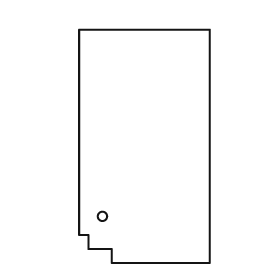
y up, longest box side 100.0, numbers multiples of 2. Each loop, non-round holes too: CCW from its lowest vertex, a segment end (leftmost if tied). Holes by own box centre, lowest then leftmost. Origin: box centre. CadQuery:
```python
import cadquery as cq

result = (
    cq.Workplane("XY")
    .moveTo(-14.0, -50.0)
    .lineTo(28.0, -50.0)
    .lineTo(28.0, 50.0)
    .lineTo(-28.0, 50.0)
    .lineTo(-28.0, -38.0)
    .lineTo(-24.0, -38.0)
    .lineTo(-24.0, -44.0)
    .lineTo(-14.0, -44.0)
    .close()
    .moveTo(-18.0, -30.0)
    .circle(2.0)
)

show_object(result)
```